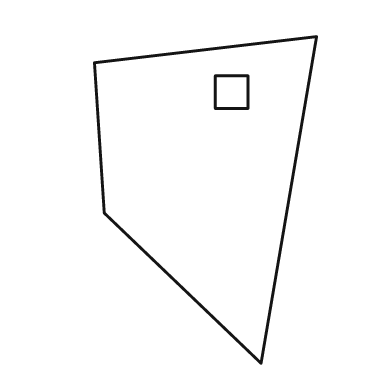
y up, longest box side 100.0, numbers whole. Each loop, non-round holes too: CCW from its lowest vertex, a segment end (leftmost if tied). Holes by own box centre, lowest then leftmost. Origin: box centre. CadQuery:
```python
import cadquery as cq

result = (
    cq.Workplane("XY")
    .moveTo(17.0, -50.0)
    .lineTo(34.0, 50.0)
    .lineTo(-34.0, 42.0)
    .lineTo(-31.0, -4.0)
    .close()
    .moveTo(3.0, 28.0)
    .lineTo(13.0, 28.0)
    .lineTo(13.0, 38.0)
    .lineTo(3.0, 38.0)
    .close()
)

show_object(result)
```